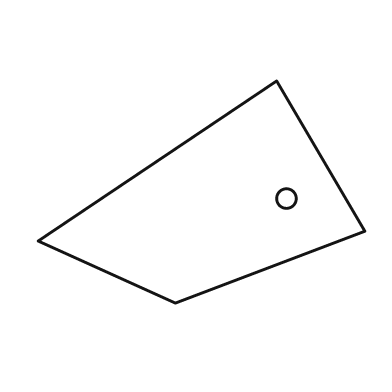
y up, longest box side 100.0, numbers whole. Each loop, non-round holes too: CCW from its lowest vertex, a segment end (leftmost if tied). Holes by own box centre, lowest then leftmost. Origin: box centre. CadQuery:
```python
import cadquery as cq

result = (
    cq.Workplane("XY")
    .moveTo(-8.0, -34.0)
    .lineTo(50.0, -12.0)
    .lineTo(23.0, 34.0)
    .lineTo(-50.0, -15.0)
    .close()
    .moveTo(26.0, -2.0)
    .circle(3.0)
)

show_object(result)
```